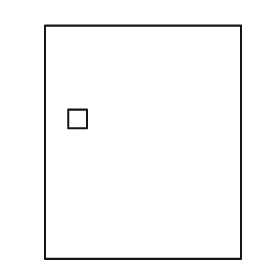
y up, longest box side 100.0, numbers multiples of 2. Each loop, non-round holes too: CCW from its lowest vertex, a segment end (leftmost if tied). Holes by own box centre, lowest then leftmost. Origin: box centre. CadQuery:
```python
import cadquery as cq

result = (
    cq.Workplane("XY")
    .moveTo(-42.0, -50.0)
    .lineTo(42.0, -50.0)
    .lineTo(42.0, 50.0)
    .lineTo(-42.0, 50.0)
    .close()
    .moveTo(-32.0, 6.0)
    .lineTo(-24.0, 6.0)
    .lineTo(-24.0, 14.0)
    .lineTo(-32.0, 14.0)
    .close()
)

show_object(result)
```